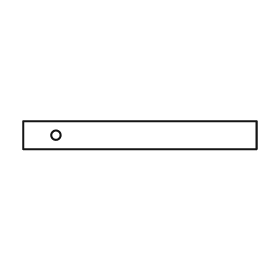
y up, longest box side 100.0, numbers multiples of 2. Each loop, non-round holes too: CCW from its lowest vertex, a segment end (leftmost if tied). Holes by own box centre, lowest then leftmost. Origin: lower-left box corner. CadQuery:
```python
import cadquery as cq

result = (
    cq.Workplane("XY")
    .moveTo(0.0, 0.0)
    .lineTo(100.0, 0.0)
    .lineTo(100.0, 12.0)
    .lineTo(0.0, 12.0)
    .close()
    .moveTo(14.0, 6.0)
    .circle(2.0)
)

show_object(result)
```